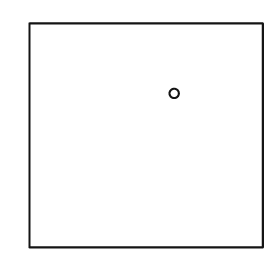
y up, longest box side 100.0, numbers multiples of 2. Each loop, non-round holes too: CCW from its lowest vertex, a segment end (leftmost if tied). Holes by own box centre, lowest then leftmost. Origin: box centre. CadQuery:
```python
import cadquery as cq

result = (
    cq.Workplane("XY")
    .moveTo(-50.0, -48.0)
    .lineTo(50.0, -48.0)
    .lineTo(50.0, 48.0)
    .lineTo(-50.0, 48.0)
    .close()
    .moveTo(12.0, 18.0)
    .circle(2.0)
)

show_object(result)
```